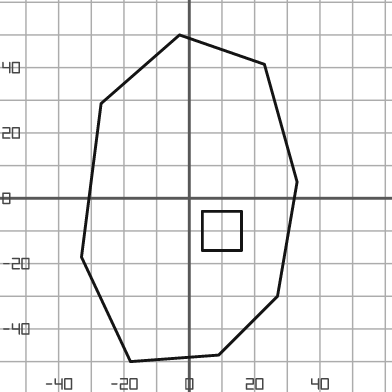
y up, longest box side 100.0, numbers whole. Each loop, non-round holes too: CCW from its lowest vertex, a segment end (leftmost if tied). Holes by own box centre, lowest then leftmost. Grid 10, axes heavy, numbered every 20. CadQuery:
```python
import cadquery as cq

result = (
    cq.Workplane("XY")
    .moveTo(-18.0, -50.0)
    .lineTo(9.0, -48.0)
    .lineTo(27.0, -30.0)
    .lineTo(33.0, 5.0)
    .lineTo(23.0, 41.0)
    .lineTo(-3.0, 50.0)
    .lineTo(-27.0, 29.0)
    .lineTo(-33.0, -18.0)
    .close()
    .moveTo(4.0, -16.0)
    .lineTo(16.0, -16.0)
    .lineTo(16.0, -4.0)
    .lineTo(4.0, -4.0)
    .close()
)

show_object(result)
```